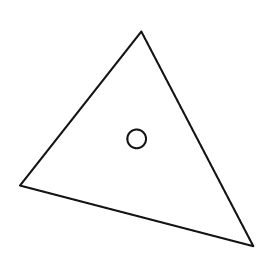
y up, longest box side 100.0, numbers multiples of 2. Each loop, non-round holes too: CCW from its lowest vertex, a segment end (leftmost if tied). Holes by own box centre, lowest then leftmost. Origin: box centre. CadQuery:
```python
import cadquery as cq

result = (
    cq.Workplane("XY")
    .moveTo(50.0, -46.0)
    .lineTo(2.0, 46.0)
    .lineTo(-50.0, -20.0)
    .close()
    .moveTo(0.0, 0.0)
    .circle(4.0)
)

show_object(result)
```